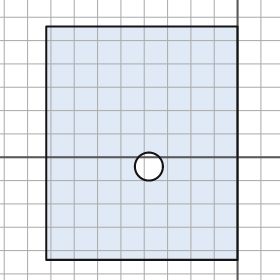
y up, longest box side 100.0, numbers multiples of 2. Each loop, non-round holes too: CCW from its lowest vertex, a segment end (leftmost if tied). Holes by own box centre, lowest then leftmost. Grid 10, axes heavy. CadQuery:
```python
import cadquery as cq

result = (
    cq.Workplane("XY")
    .moveTo(-82.0, -44.0)
    .lineTo(0.0, -44.0)
    .lineTo(0.0, 56.0)
    .lineTo(-82.0, 56.0)
    .close()
    .moveTo(-38.0, -4.0)
    .circle(6.0)
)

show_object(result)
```